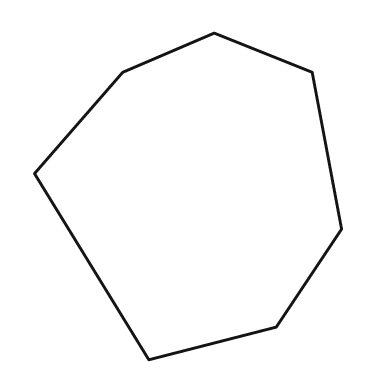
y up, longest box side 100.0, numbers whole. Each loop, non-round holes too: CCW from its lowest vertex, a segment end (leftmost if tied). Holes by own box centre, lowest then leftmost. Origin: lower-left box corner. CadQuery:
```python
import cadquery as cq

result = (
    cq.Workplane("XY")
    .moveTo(35.0, 0.0)
    .lineTo(74.0, 10.0)
    .lineTo(94.0, 40.0)
    .lineTo(85.0, 88.0)
    .lineTo(55.0, 100.0)
    .lineTo(27.0, 88.0)
    .lineTo(0.0, 57.0)
    .close()
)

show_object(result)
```